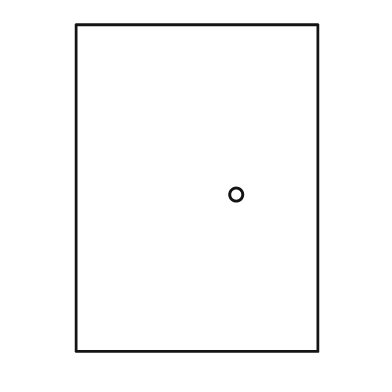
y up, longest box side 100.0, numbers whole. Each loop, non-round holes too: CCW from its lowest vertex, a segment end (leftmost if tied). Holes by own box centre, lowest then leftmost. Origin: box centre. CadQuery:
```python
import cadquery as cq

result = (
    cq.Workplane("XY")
    .moveTo(-37.0, -50.0)
    .lineTo(37.0, -50.0)
    .lineTo(37.0, 50.0)
    .lineTo(-37.0, 50.0)
    .close()
    .moveTo(12.0, -2.0)
    .circle(2.0)
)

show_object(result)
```